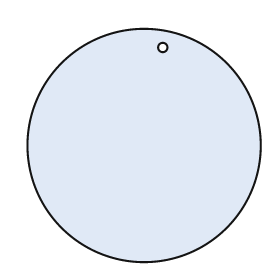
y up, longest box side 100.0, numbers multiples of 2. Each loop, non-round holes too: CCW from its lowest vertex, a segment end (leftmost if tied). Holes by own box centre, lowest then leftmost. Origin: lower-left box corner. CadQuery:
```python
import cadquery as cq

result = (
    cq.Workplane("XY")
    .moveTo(50.0, 50.0)
    .circle(50.0)
    .moveTo(58.0, 92.0)
    .circle(2.0)
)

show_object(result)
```